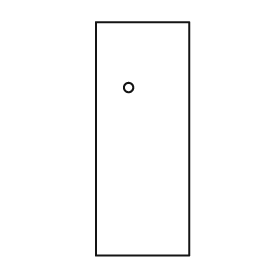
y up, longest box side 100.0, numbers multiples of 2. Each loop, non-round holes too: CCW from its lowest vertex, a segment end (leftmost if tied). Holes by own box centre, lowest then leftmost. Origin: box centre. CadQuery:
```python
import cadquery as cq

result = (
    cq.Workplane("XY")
    .moveTo(-20.0, -50.0)
    .lineTo(20.0, -50.0)
    .lineTo(20.0, 50.0)
    .lineTo(-20.0, 50.0)
    .close()
    .moveTo(-6.0, 22.0)
    .circle(2.0)
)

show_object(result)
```